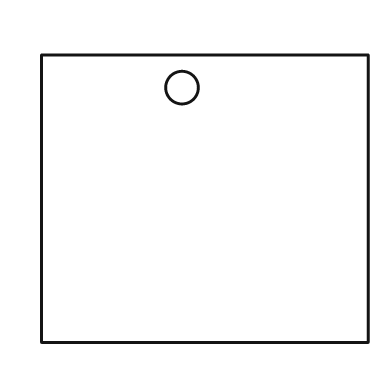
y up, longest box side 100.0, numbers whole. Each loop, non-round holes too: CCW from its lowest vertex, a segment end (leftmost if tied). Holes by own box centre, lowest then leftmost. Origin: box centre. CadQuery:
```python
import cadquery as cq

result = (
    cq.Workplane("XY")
    .moveTo(-50.0, -44.0)
    .lineTo(50.0, -44.0)
    .lineTo(50.0, 44.0)
    .lineTo(-50.0, 44.0)
    .close()
    .moveTo(-7.0, 34.0)
    .circle(5.0)
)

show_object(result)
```